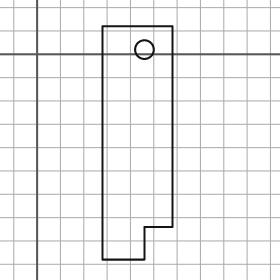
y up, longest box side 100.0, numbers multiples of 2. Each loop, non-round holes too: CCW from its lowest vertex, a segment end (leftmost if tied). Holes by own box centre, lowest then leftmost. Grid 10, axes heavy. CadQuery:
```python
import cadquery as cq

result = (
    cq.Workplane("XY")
    .moveTo(28.0, -88.0)
    .lineTo(46.0, -88.0)
    .lineTo(46.0, -74.0)
    .lineTo(58.0, -74.0)
    .lineTo(58.0, 12.0)
    .lineTo(28.0, 12.0)
    .close()
    .moveTo(46.0, 2.0)
    .circle(4.0)
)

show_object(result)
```